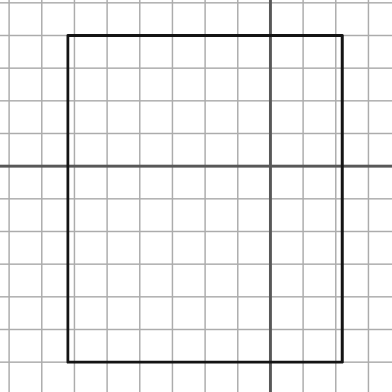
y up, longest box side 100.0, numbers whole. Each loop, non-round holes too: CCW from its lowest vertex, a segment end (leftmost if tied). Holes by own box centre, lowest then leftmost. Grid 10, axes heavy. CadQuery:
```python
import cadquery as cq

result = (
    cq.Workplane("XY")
    .moveTo(-62.0, -60.0)
    .lineTo(22.0, -60.0)
    .lineTo(22.0, 40.0)
    .lineTo(-62.0, 40.0)
    .close()
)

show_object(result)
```